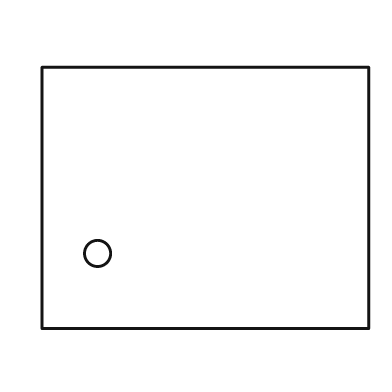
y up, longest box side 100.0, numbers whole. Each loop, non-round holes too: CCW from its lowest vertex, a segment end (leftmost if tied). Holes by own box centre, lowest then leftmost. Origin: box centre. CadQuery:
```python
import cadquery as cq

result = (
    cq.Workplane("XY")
    .moveTo(-50.0, -40.0)
    .lineTo(50.0, -40.0)
    .lineTo(50.0, 40.0)
    .lineTo(-50.0, 40.0)
    .close()
    .moveTo(-33.0, -17.0)
    .circle(4.0)
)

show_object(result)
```